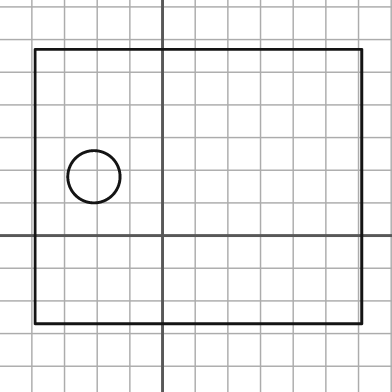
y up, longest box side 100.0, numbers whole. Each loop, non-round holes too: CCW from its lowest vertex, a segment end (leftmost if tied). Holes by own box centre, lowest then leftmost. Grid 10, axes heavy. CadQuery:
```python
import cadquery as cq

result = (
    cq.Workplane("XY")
    .moveTo(-39.0, -27.0)
    .lineTo(61.0, -27.0)
    .lineTo(61.0, 57.0)
    .lineTo(-39.0, 57.0)
    .close()
    .moveTo(-21.0, 18.0)
    .circle(8.0)
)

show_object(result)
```